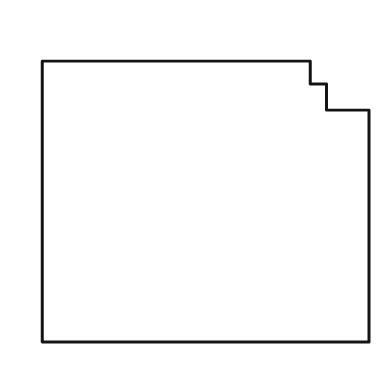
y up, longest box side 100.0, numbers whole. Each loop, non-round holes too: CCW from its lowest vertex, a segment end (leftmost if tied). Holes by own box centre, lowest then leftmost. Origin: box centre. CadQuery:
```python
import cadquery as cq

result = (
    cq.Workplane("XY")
    .moveTo(-50.0, -43.0)
    .lineTo(50.0, -43.0)
    .lineTo(50.0, 28.0)
    .lineTo(37.0, 28.0)
    .lineTo(37.0, 36.0)
    .lineTo(32.0, 36.0)
    .lineTo(32.0, 43.0)
    .lineTo(-50.0, 43.0)
    .close()
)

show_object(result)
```